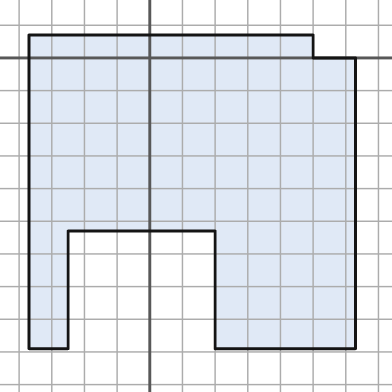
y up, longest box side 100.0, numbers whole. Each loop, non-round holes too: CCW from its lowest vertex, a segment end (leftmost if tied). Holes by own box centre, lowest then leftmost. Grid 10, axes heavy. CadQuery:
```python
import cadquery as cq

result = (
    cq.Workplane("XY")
    .moveTo(-37.0, -89.0)
    .lineTo(-25.0, -89.0)
    .lineTo(-25.0, -53.0)
    .lineTo(20.0, -53.0)
    .lineTo(20.0, -89.0)
    .lineTo(63.0, -89.0)
    .lineTo(63.0, 0.0)
    .lineTo(50.0, 0.0)
    .lineTo(50.0, 7.0)
    .lineTo(-37.0, 7.0)
    .close()
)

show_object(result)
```